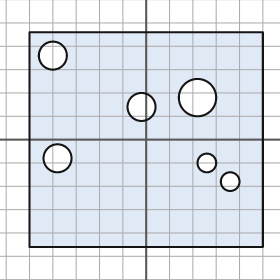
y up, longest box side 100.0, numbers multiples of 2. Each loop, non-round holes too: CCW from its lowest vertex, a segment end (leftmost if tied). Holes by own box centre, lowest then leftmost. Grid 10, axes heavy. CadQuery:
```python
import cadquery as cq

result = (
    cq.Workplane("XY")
    .moveTo(-50.0, -46.0)
    .lineTo(50.0, -46.0)
    .lineTo(50.0, 46.0)
    .lineTo(-50.0, 46.0)
    .close()
    .moveTo(36.0, -18.0)
    .circle(4.0)
    .moveTo(26.0, -10.0)
    .circle(4.0)
    .moveTo(-38.0, -8.0)
    .circle(6.0)
    .moveTo(-2.0, 14.0)
    .circle(6.0)
    .moveTo(22.0, 18.0)
    .circle(8.0)
    .moveTo(-40.0, 36.0)
    .circle(6.0)
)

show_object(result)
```